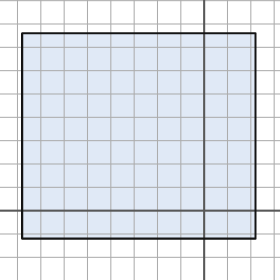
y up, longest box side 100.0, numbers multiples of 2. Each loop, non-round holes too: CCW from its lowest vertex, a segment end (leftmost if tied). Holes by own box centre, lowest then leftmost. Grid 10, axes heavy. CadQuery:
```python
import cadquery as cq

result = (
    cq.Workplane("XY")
    .moveTo(-78.0, -12.0)
    .lineTo(22.0, -12.0)
    .lineTo(22.0, 76.0)
    .lineTo(-78.0, 76.0)
    .close()
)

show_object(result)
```